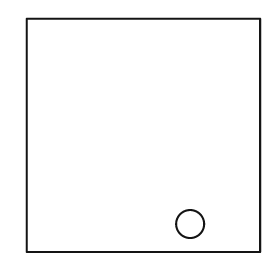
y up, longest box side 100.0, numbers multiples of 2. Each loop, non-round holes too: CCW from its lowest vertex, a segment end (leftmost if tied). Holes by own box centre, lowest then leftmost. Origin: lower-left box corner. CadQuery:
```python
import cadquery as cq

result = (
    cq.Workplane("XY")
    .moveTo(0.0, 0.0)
    .lineTo(100.0, 0.0)
    .lineTo(100.0, 100.0)
    .lineTo(0.0, 100.0)
    .close()
    .moveTo(70.0, 12.0)
    .circle(6.0)
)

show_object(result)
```